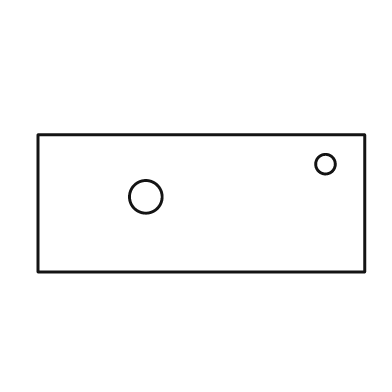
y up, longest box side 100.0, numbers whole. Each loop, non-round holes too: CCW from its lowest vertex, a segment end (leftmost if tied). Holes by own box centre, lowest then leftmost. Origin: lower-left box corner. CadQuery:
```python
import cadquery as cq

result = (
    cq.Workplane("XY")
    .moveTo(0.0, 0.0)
    .lineTo(100.0, 0.0)
    .lineTo(100.0, 42.0)
    .lineTo(0.0, 42.0)
    .close()
    .moveTo(33.0, 23.0)
    .circle(5.0)
    .moveTo(88.0, 33.0)
    .circle(3.0)
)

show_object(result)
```